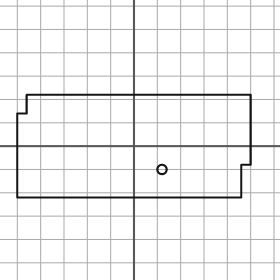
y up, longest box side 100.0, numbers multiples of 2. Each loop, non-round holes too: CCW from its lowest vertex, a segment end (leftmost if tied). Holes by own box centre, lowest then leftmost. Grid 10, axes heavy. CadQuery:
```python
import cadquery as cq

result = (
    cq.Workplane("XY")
    .moveTo(-50.0, -22.0)
    .lineTo(46.0, -22.0)
    .lineTo(46.0, -8.0)
    .lineTo(50.0, -8.0)
    .lineTo(50.0, 22.0)
    .lineTo(-46.0, 22.0)
    .lineTo(-46.0, 14.0)
    .lineTo(-50.0, 14.0)
    .close()
    .moveTo(12.0, -10.0)
    .circle(2.0)
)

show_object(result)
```